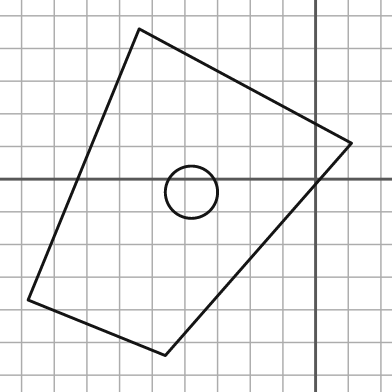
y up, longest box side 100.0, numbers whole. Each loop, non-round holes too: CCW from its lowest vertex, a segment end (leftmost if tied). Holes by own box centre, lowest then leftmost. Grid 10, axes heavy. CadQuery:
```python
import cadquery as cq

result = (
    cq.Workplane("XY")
    .moveTo(-46.0, -54.0)
    .lineTo(11.0, 11.0)
    .lineTo(-54.0, 46.0)
    .lineTo(-88.0, -37.0)
    .close()
    .moveTo(-38.0, -4.0)
    .circle(8.0)
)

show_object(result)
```